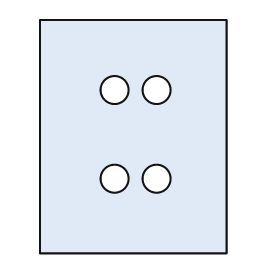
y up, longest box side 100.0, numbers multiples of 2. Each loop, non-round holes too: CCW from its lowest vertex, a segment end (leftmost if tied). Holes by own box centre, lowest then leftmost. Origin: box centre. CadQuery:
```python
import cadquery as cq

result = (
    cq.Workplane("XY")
    .moveTo(-40.0, -50.0)
    .lineTo(40.0, -50.0)
    .lineTo(40.0, 50.0)
    .lineTo(-40.0, 50.0)
    .close()
    .moveTo(-8.0, -18.0)
    .circle(6.0)
    .moveTo(10.0, -18.0)
    .circle(6.0)
    .moveTo(-8.0, 20.0)
    .circle(6.0)
    .moveTo(10.0, 20.0)
    .circle(6.0)
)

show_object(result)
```